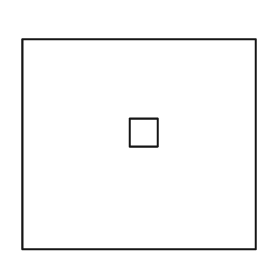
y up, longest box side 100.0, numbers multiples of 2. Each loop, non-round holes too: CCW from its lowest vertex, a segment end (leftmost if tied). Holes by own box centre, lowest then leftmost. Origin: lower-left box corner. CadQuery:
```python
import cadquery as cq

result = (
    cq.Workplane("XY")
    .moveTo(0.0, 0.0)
    .lineTo(100.0, 0.0)
    .lineTo(100.0, 90.0)
    .lineTo(0.0, 90.0)
    .close()
    .moveTo(46.0, 44.0)
    .lineTo(58.0, 44.0)
    .lineTo(58.0, 56.0)
    .lineTo(46.0, 56.0)
    .close()
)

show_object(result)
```